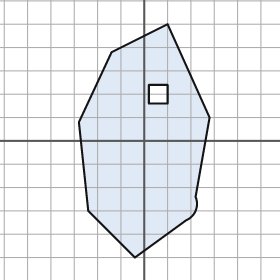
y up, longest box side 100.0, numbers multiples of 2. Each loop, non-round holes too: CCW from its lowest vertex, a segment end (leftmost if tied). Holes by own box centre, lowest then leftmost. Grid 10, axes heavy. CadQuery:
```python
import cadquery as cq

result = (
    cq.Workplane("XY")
    .moveTo(-4.0, -50.0)
    .lineTo(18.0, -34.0)
    .threePointArc((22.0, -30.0), (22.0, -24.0))
    .lineTo(28.0, 10.0)
    .lineTo(10.0, 50.0)
    .lineTo(-14.0, 38.0)
    .lineTo(-28.0, 8.0)
    .lineTo(-24.0, -30.0)
    .close()
    .moveTo(2.0, 16.0)
    .lineTo(10.0, 16.0)
    .lineTo(10.0, 24.0)
    .lineTo(2.0, 24.0)
    .close()
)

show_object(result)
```